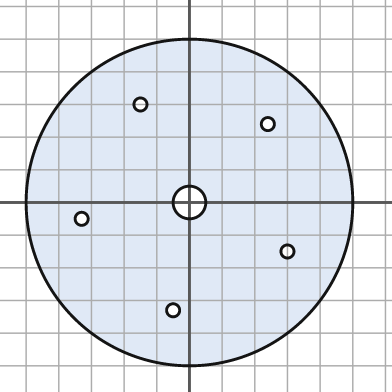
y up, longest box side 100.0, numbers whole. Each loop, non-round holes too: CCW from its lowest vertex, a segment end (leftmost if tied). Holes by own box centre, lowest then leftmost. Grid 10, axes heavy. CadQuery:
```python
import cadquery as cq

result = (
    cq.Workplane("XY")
    .moveTo(0.0, 0.0)
    .circle(50.0)
    .moveTo(-5.0, -33.0)
    .circle(2.0)
    .moveTo(30.0, -15.0)
    .circle(2.0)
    .moveTo(-33.0, -5.0)
    .circle(2.0)
    .moveTo(0.0, 0.0)
    .circle(5.0)
    .moveTo(24.0, 24.0)
    .circle(2.0)
    .moveTo(-15.0, 30.0)
    .circle(2.0)
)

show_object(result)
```